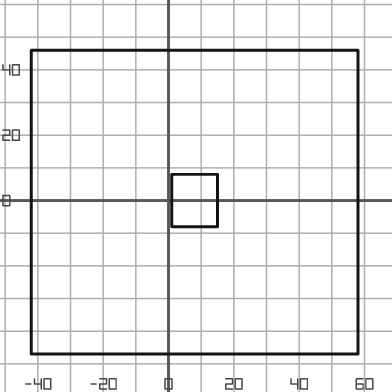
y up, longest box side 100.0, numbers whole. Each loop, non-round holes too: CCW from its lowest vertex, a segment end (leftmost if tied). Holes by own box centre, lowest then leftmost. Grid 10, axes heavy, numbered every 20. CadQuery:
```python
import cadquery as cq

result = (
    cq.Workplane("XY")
    .moveTo(-42.0, -47.0)
    .lineTo(58.0, -47.0)
    .lineTo(58.0, 46.0)
    .lineTo(-42.0, 46.0)
    .close()
    .moveTo(1.0, -8.0)
    .lineTo(15.0, -8.0)
    .lineTo(15.0, 8.0)
    .lineTo(1.0, 8.0)
    .close()
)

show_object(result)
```